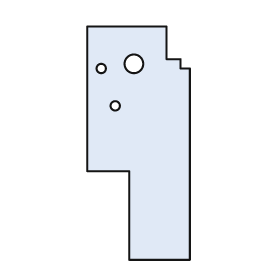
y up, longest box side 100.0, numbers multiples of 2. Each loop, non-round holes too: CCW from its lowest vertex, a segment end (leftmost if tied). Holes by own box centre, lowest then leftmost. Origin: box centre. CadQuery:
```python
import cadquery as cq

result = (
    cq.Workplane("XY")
    .moveTo(-4.0, -50.0)
    .lineTo(22.0, -50.0)
    .lineTo(22.0, 32.0)
    .lineTo(18.0, 32.0)
    .lineTo(18.0, 36.0)
    .lineTo(12.0, 36.0)
    .lineTo(12.0, 50.0)
    .lineTo(-22.0, 50.0)
    .lineTo(-22.0, -12.0)
    .lineTo(-4.0, -12.0)
    .close()
    .moveTo(-10.0, 16.0)
    .circle(2.0)
    .moveTo(-16.0, 32.0)
    .circle(2.0)
    .moveTo(-2.0, 34.0)
    .circle(4.0)
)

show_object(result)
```